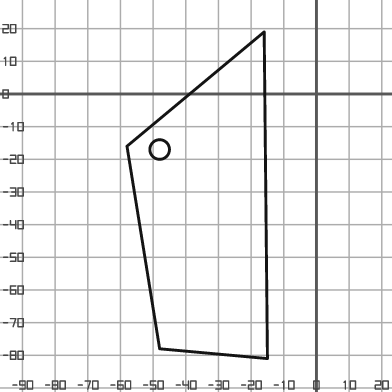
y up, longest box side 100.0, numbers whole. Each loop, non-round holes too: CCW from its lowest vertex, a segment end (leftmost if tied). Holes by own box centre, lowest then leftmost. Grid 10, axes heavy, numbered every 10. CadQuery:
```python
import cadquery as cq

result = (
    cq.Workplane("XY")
    .moveTo(-15.0, -81.0)
    .lineTo(-16.0, 19.0)
    .lineTo(-58.0, -16.0)
    .lineTo(-48.0, -78.0)
    .close()
    .moveTo(-48.0, -17.0)
    .circle(3.0)
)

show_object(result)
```